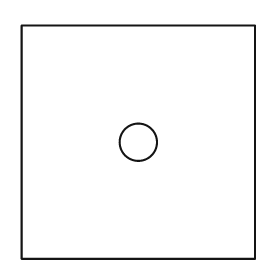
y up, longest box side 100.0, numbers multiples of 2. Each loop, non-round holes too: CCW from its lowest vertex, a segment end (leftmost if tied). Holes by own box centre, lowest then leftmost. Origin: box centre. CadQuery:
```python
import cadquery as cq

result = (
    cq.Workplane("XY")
    .moveTo(-50.0, -50.0)
    .lineTo(50.0, -50.0)
    .lineTo(50.0, 50.0)
    .lineTo(-50.0, 50.0)
    .close()
    .moveTo(0.0, 0.0)
    .circle(8.0)
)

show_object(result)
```